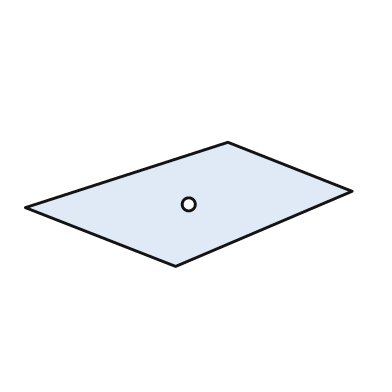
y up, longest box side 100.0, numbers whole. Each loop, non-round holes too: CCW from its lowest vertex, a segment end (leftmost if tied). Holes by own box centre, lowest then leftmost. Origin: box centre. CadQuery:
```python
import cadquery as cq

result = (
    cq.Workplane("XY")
    .moveTo(-4.0, -19.0)
    .lineTo(50.0, 4.0)
    .lineTo(12.0, 19.0)
    .lineTo(-50.0, -1.0)
    .close()
    .moveTo(0.0, 0.0)
    .circle(2.0)
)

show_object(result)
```